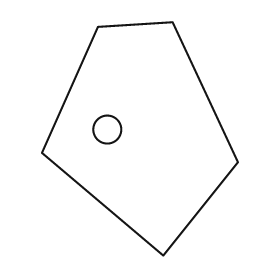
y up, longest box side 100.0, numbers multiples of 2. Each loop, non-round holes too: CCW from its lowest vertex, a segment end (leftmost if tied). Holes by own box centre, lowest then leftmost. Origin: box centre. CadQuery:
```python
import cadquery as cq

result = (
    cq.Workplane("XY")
    .moveTo(10.0, -50.0)
    .lineTo(42.0, -10.0)
    .lineTo(14.0, 50.0)
    .lineTo(-18.0, 48.0)
    .lineTo(-42.0, -6.0)
    .close()
    .moveTo(-14.0, 4.0)
    .circle(6.0)
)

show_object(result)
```